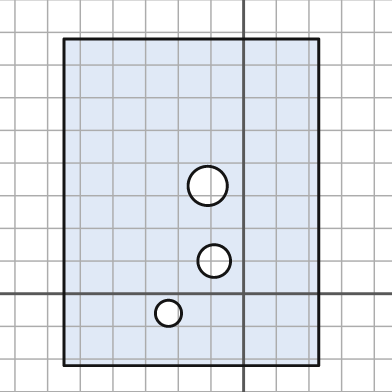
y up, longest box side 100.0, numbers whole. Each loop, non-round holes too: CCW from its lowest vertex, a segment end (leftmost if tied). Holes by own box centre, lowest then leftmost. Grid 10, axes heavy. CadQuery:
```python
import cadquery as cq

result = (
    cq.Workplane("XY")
    .moveTo(-55.0, -22.0)
    .lineTo(23.0, -22.0)
    .lineTo(23.0, 78.0)
    .lineTo(-55.0, 78.0)
    .close()
    .moveTo(-23.0, -6.0)
    .circle(4.0)
    .moveTo(-9.0, 10.0)
    .circle(5.0)
    .moveTo(-11.0, 33.0)
    .circle(6.0)
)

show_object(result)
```